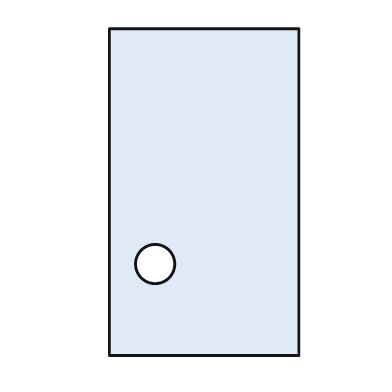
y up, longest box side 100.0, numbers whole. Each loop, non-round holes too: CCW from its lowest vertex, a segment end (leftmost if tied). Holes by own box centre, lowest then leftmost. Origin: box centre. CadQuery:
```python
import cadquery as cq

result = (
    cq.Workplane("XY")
    .moveTo(-29.0, -50.0)
    .lineTo(29.0, -50.0)
    .lineTo(29.0, 50.0)
    .lineTo(-29.0, 50.0)
    .close()
    .moveTo(-15.0, -22.0)
    .circle(6.0)
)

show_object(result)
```